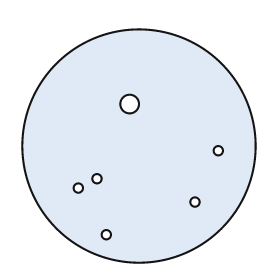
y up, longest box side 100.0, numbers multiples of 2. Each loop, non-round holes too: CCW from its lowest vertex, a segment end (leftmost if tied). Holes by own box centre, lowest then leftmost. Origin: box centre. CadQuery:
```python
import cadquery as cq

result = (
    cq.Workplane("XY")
    .moveTo(0.0, 0.0)
    .circle(50.0)
    .moveTo(-14.0, -38.0)
    .circle(2.0)
    .moveTo(24.0, -24.0)
    .circle(2.0)
    .moveTo(-26.0, -18.0)
    .circle(2.0)
    .moveTo(-18.0, -14.0)
    .circle(2.0)
    .moveTo(34.0, -2.0)
    .circle(2.0)
    .moveTo(-4.0, 18.0)
    .circle(4.0)
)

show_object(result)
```